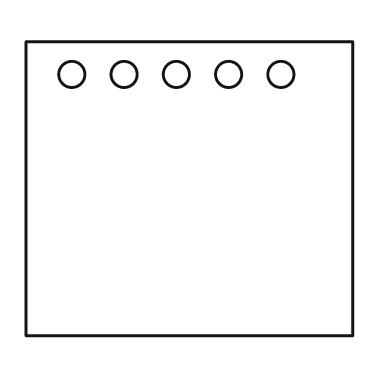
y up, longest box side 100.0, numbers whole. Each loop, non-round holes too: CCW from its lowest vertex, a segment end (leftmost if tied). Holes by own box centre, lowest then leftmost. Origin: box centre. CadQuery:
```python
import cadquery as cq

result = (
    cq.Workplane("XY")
    .moveTo(-50.0, -45.0)
    .lineTo(50.0, -45.0)
    .lineTo(50.0, 45.0)
    .lineTo(-50.0, 45.0)
    .close()
    .moveTo(-36.0, 35.0)
    .circle(4.0)
    .moveTo(-20.0, 35.0)
    .circle(4.0)
    .moveTo(-4.0, 35.0)
    .circle(4.0)
    .moveTo(12.0, 35.0)
    .circle(4.0)
    .moveTo(28.0, 35.0)
    .circle(4.0)
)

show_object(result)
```